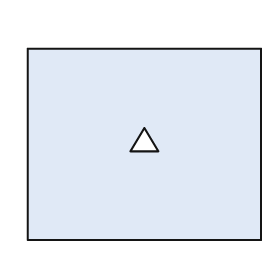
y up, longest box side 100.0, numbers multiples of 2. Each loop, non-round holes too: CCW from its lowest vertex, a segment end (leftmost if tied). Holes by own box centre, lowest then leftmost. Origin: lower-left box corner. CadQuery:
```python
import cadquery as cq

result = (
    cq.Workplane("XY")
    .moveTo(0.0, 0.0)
    .lineTo(100.0, 0.0)
    .lineTo(100.0, 82.0)
    .lineTo(0.0, 82.0)
    .close()
    .moveTo(44.0, 38.0)
    .lineTo(56.0, 38.0)
    .lineTo(50.0, 48.0)
    .close()
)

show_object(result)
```